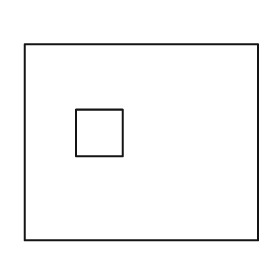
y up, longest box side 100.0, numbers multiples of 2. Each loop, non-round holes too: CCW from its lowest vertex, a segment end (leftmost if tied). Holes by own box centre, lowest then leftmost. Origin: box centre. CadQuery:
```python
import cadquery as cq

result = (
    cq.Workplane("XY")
    .moveTo(-50.0, -42.0)
    .lineTo(50.0, -42.0)
    .lineTo(50.0, 42.0)
    .lineTo(-50.0, 42.0)
    .close()
    .moveTo(-28.0, -6.0)
    .lineTo(-8.0, -6.0)
    .lineTo(-8.0, 14.0)
    .lineTo(-28.0, 14.0)
    .close()
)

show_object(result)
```